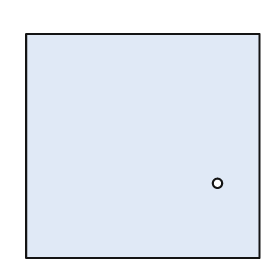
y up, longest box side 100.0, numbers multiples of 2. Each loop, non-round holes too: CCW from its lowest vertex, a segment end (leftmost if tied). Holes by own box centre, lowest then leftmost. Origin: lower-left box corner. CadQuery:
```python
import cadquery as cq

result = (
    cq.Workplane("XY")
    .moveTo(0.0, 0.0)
    .lineTo(100.0, 0.0)
    .lineTo(100.0, 96.0)
    .lineTo(0.0, 96.0)
    .close()
    .moveTo(82.0, 32.0)
    .circle(2.0)
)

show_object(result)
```